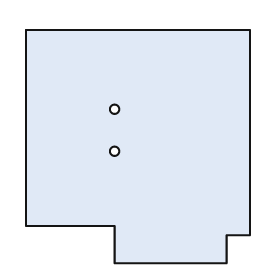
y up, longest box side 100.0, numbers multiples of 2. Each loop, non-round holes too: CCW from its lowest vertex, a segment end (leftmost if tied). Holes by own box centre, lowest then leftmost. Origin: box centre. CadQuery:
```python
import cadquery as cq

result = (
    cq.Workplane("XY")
    .moveTo(-10.0, -50.0)
    .lineTo(38.0, -50.0)
    .lineTo(38.0, -38.0)
    .lineTo(48.0, -38.0)
    .lineTo(48.0, 50.0)
    .lineTo(-48.0, 50.0)
    .lineTo(-48.0, -34.0)
    .lineTo(-10.0, -34.0)
    .close()
    .moveTo(-10.0, -2.0)
    .circle(2.0)
    .moveTo(-10.0, 16.0)
    .circle(2.0)
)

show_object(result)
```